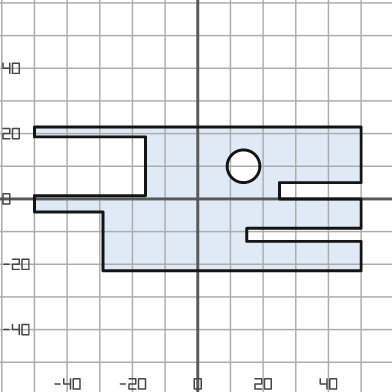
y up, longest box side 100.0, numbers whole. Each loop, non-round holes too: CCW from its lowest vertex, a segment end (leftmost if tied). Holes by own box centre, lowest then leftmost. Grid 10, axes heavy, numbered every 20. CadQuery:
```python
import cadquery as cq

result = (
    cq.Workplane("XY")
    .moveTo(-29.0, -22.0)
    .lineTo(50.0, -22.0)
    .lineTo(50.0, -13.0)
    .lineTo(15.0, -13.0)
    .lineTo(15.0, -9.0)
    .lineTo(50.0, -9.0)
    .lineTo(50.0, 0.0)
    .lineTo(25.0, 0.0)
    .lineTo(25.0, 5.0)
    .lineTo(50.0, 5.0)
    .lineTo(50.0, 22.0)
    .lineTo(-50.0, 22.0)
    .lineTo(-50.0, 19.0)
    .lineTo(-16.0, 19.0)
    .lineTo(-16.0, 1.0)
    .lineTo(-50.0, 1.0)
    .lineTo(-50.0, -4.0)
    .lineTo(-29.0, -4.0)
    .close()
    .moveTo(14.0, 10.0)
    .circle(5.0)
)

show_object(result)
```